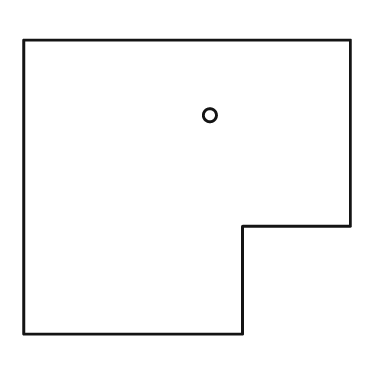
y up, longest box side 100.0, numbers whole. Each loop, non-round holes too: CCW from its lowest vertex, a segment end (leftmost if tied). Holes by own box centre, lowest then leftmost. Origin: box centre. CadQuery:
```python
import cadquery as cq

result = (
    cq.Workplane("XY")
    .moveTo(-50.0, -45.0)
    .lineTo(17.0, -45.0)
    .lineTo(17.0, -12.0)
    .lineTo(50.0, -12.0)
    .lineTo(50.0, 45.0)
    .lineTo(-50.0, 45.0)
    .close()
    .moveTo(7.0, 22.0)
    .circle(2.0)
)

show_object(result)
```